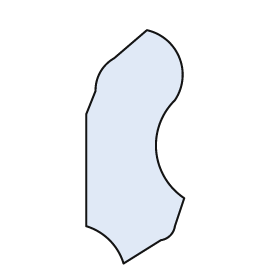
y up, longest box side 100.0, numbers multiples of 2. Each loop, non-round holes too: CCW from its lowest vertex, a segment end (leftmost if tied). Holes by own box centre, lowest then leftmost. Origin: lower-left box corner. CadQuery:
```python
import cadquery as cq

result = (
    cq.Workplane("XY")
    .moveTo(16.0, 0.0)
    .lineTo(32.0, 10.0)
    .threePointArc((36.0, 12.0), (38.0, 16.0))
    .lineTo(42.0, 28.0)
    .threePointArc((30.0, 48.0), (38.0, 70.0))
    .threePointArc((40.0, 88.0), (26.0, 100.0))
    .lineTo(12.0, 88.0)
    .threePointArc((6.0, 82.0), (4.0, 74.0))
    .lineTo(0.0, 64.0)
    .lineTo(0.0, 16.0)
    .threePointArc((10.0, 10.0), (16.0, 0.0))
    .close()
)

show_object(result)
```